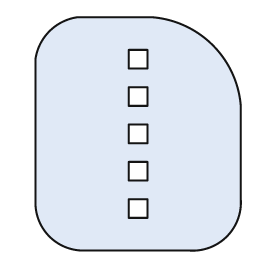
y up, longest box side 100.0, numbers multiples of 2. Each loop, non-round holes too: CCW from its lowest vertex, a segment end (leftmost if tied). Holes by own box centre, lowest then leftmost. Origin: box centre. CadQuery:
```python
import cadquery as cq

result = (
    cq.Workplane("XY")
    .moveTo(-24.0, -50.0)
    .lineTo(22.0, -50.0)
    .threePointArc((38.0, -44.0), (44.0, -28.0))
    .lineTo(44.0, 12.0)
    .threePointArc((32.0, 38.0), (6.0, 50.0))
    .lineTo(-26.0, 50.0)
    .threePointArc((-38.0, 44.0), (-44.0, 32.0))
    .lineTo(-44.0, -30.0)
    .threePointArc((-38.0, -44.0), (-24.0, -50.0))
    .close()
    .moveTo(-4.0, -36.0)
    .lineTo(4.0, -36.0)
    .lineTo(4.0, -28.0)
    .lineTo(-4.0, -28.0)
    .close()
    .moveTo(-4.0, -20.0)
    .lineTo(4.0, -20.0)
    .lineTo(4.0, -12.0)
    .lineTo(-4.0, -12.0)
    .close()
    .moveTo(-4.0, -4.0)
    .lineTo(4.0, -4.0)
    .lineTo(4.0, 4.0)
    .lineTo(-4.0, 4.0)
    .close()
    .moveTo(-4.0, 12.0)
    .lineTo(4.0, 12.0)
    .lineTo(4.0, 20.0)
    .lineTo(-4.0, 20.0)
    .close()
    .moveTo(-4.0, 28.0)
    .lineTo(4.0, 28.0)
    .lineTo(4.0, 36.0)
    .lineTo(-4.0, 36.0)
    .close()
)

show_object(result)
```